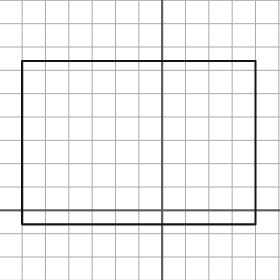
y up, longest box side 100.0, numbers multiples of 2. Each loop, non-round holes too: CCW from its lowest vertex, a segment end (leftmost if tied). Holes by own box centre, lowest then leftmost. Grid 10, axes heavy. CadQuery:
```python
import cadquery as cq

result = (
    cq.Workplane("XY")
    .moveTo(-60.0, -6.0)
    .lineTo(40.0, -6.0)
    .lineTo(40.0, 64.0)
    .lineTo(-60.0, 64.0)
    .close()
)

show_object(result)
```